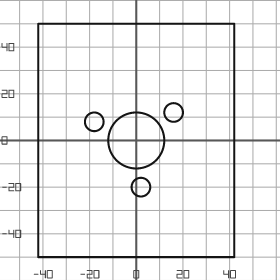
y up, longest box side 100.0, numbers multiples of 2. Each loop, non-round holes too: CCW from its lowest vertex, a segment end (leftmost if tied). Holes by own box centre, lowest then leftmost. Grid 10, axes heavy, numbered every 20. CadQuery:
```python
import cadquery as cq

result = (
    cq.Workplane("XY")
    .moveTo(-42.0, -50.0)
    .lineTo(42.0, -50.0)
    .lineTo(42.0, 50.0)
    .lineTo(-42.0, 50.0)
    .close()
    .moveTo(2.0, -20.0)
    .circle(4.0)
    .moveTo(0.0, 0.0)
    .circle(12.0)
    .moveTo(-18.0, 8.0)
    .circle(4.0)
    .moveTo(16.0, 12.0)
    .circle(4.0)
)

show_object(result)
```